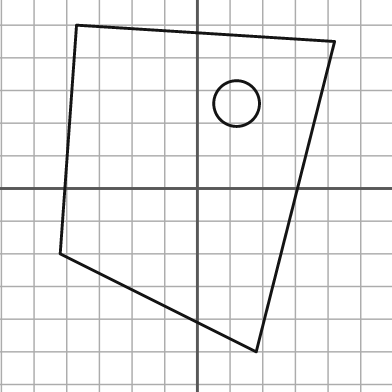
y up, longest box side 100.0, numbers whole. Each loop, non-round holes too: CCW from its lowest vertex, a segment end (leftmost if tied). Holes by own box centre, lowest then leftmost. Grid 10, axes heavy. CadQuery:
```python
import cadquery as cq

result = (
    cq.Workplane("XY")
    .moveTo(18.0, -50.0)
    .lineTo(42.0, 45.0)
    .lineTo(-37.0, 50.0)
    .lineTo(-42.0, -20.0)
    .close()
    .moveTo(12.0, 26.0)
    .circle(7.0)
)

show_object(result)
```